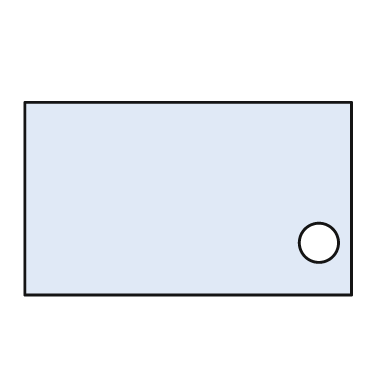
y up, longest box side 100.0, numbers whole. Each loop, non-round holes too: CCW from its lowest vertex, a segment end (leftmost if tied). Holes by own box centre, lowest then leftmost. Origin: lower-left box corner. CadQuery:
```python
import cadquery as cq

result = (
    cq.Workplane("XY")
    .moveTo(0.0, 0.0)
    .lineTo(100.0, 0.0)
    .lineTo(100.0, 59.0)
    .lineTo(0.0, 59.0)
    .close()
    .moveTo(90.0, 16.0)
    .circle(6.0)
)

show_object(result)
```